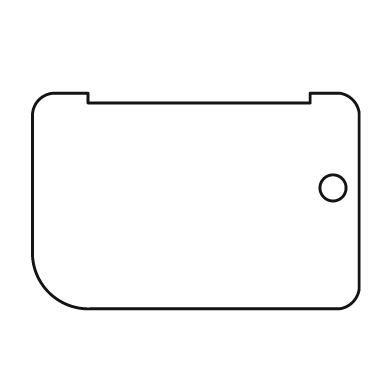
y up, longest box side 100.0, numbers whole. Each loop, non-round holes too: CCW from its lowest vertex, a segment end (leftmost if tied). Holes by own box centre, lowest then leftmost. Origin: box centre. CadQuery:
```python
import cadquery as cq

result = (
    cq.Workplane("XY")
    .moveTo(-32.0, -33.0)
    .lineTo(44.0, -33.0)
    .threePointArc((48.0, -31.0), (50.0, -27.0))
    .lineTo(50.0, 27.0)
    .threePointArc((48.0, 31.0), (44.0, 33.0))
    .lineTo(35.0, 33.0)
    .lineTo(35.0, 30.0)
    .lineTo(-33.0, 30.0)
    .lineTo(-33.0, 33.0)
    .lineTo(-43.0, 33.0)
    .threePointArc((-48.0, 31.0), (-50.0, 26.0))
    .lineTo(-50.0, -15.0)
    .threePointArc((-45.0, -28.0), (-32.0, -33.0))
    .close()
    .moveTo(42.0, 4.0)
    .circle(4.0)
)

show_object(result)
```